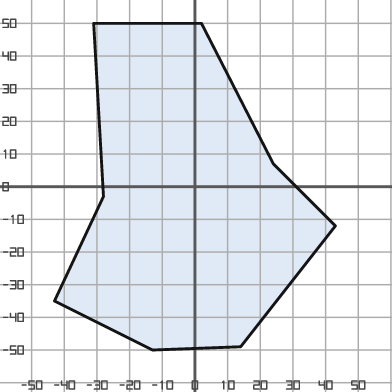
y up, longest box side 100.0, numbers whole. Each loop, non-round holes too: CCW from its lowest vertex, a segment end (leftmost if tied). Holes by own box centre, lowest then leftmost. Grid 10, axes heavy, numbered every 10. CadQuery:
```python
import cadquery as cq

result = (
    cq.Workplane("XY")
    .moveTo(-13.0, -50.0)
    .lineTo(14.0, -49.0)
    .lineTo(43.0, -12.0)
    .lineTo(24.0, 7.0)
    .lineTo(2.0, 50.0)
    .lineTo(-31.0, 50.0)
    .lineTo(-28.0, -3.0)
    .lineTo(-43.0, -35.0)
    .close()
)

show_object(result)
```